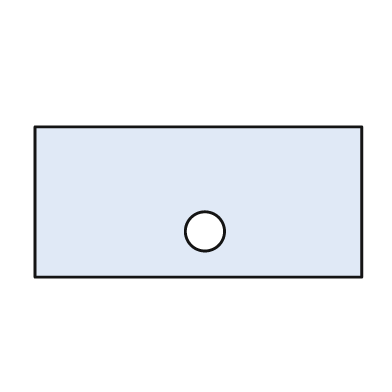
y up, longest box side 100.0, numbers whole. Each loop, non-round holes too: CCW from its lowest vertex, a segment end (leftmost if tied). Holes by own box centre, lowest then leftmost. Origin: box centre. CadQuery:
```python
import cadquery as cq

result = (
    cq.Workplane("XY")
    .moveTo(-50.0, -23.0)
    .lineTo(50.0, -23.0)
    .lineTo(50.0, 23.0)
    .lineTo(-50.0, 23.0)
    .close()
    .moveTo(2.0, -9.0)
    .circle(6.0)
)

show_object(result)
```